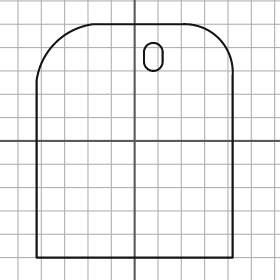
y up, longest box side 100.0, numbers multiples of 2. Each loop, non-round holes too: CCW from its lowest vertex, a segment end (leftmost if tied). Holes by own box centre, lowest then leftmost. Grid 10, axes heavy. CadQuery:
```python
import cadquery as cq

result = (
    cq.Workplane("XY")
    .moveTo(-42.0, -50.0)
    .lineTo(42.0, -50.0)
    .lineTo(42.0, 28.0)
    .threePointArc((36.0, 44.0), (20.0, 50.0))
    .lineTo(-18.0, 50.0)
    .threePointArc((-34.0, 42.0), (-42.0, 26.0))
    .close()
    .moveTo(4.0, 34.0)
    .threePointArc((8.0, 30.0), (12.0, 34.0))
    .lineTo(12.0, 38.0)
    .threePointArc((8.0, 42.0), (4.0, 38.0))
    .close()
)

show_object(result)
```